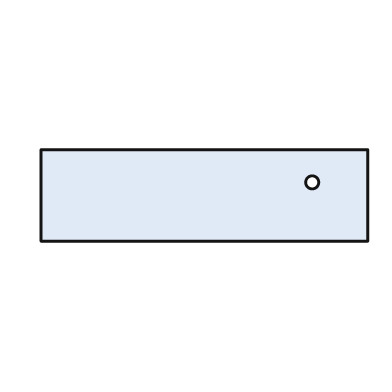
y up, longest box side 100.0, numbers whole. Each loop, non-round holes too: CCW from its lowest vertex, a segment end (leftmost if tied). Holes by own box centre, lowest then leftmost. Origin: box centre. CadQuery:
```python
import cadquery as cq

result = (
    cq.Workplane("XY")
    .moveTo(-50.0, -14.0)
    .lineTo(50.0, -14.0)
    .lineTo(50.0, 14.0)
    .lineTo(-50.0, 14.0)
    .close()
    .moveTo(33.0, 4.0)
    .circle(2.0)
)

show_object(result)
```